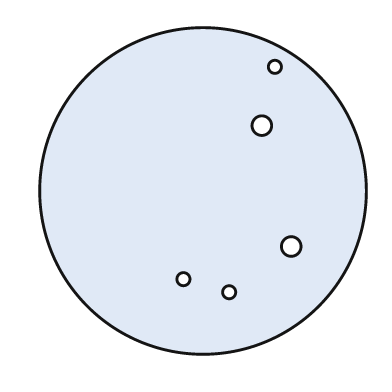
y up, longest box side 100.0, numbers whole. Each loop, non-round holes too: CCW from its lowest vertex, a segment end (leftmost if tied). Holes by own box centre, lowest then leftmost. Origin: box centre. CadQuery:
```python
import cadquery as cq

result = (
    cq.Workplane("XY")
    .moveTo(0.0, 0.0)
    .circle(50.0)
    .moveTo(8.0, -31.0)
    .circle(2.0)
    .moveTo(-6.0, -27.0)
    .circle(2.0)
    .moveTo(27.0, -17.0)
    .circle(3.0)
    .moveTo(18.0, 20.0)
    .circle(3.0)
    .moveTo(22.0, 38.0)
    .circle(2.0)
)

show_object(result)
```